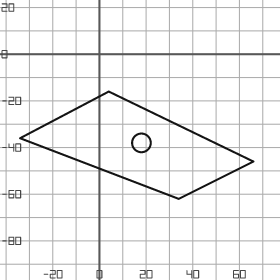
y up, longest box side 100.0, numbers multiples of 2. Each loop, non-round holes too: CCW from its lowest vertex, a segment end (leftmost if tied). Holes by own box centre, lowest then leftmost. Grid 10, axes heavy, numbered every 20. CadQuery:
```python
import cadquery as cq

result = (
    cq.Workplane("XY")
    .moveTo(34.0, -62.0)
    .lineTo(66.0, -46.0)
    .lineTo(4.0, -16.0)
    .lineTo(-34.0, -36.0)
    .close()
    .moveTo(18.0, -38.0)
    .circle(4.0)
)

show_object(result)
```